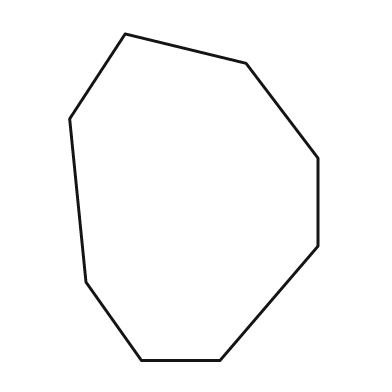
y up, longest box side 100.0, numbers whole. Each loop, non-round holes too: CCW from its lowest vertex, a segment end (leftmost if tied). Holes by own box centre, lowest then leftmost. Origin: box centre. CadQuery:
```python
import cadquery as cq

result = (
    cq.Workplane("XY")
    .moveTo(-16.0, -50.0)
    .lineTo(8.0, -50.0)
    .lineTo(38.0, -15.0)
    .lineTo(38.0, 12.0)
    .lineTo(16.0, 41.0)
    .lineTo(-21.0, 50.0)
    .lineTo(-38.0, 24.0)
    .lineTo(-33.0, -26.0)
    .close()
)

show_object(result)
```